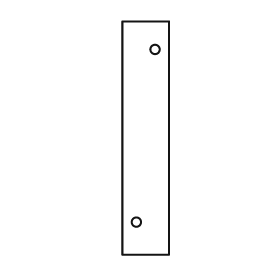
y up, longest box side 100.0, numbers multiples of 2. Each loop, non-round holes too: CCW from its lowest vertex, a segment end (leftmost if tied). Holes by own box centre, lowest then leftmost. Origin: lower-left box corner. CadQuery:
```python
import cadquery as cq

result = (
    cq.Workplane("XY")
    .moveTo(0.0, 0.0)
    .lineTo(20.0, 0.0)
    .lineTo(20.0, 100.0)
    .lineTo(0.0, 100.0)
    .close()
    .moveTo(6.0, 14.0)
    .circle(2.0)
    .moveTo(14.0, 88.0)
    .circle(2.0)
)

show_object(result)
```